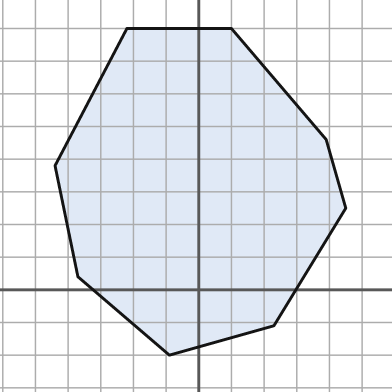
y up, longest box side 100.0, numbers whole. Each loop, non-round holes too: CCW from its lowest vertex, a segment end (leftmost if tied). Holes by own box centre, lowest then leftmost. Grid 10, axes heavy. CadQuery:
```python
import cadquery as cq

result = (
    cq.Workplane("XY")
    .moveTo(-9.0, -20.0)
    .lineTo(23.0, -11.0)
    .lineTo(45.0, 25.0)
    .lineTo(39.0, 46.0)
    .lineTo(10.0, 80.0)
    .lineTo(-22.0, 80.0)
    .lineTo(-44.0, 38.0)
    .lineTo(-37.0, 4.0)
    .close()
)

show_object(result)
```